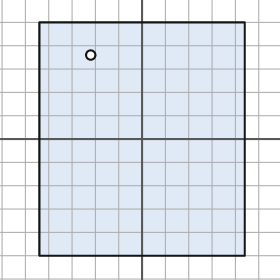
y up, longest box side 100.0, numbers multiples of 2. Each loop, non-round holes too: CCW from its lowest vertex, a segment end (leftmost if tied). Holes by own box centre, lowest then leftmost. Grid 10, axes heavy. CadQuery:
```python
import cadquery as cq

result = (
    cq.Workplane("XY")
    .moveTo(-44.0, -50.0)
    .lineTo(44.0, -50.0)
    .lineTo(44.0, 50.0)
    .lineTo(-44.0, 50.0)
    .close()
    .moveTo(-22.0, 36.0)
    .circle(2.0)
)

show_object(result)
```